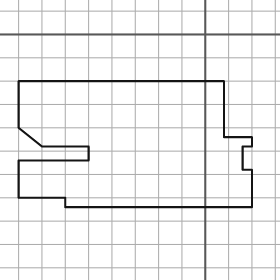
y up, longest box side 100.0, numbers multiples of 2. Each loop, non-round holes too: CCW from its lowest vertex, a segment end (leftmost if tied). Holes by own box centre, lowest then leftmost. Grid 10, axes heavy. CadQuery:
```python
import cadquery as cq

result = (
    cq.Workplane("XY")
    .moveTo(-60.0, -74.0)
    .lineTo(20.0, -74.0)
    .lineTo(20.0, -58.0)
    .lineTo(16.0, -58.0)
    .lineTo(16.0, -48.0)
    .lineTo(20.0, -48.0)
    .lineTo(20.0, -44.0)
    .lineTo(8.0, -44.0)
    .lineTo(8.0, -20.0)
    .lineTo(-80.0, -20.0)
    .lineTo(-80.0, -40.0)
    .lineTo(-70.0, -48.0)
    .lineTo(-50.0, -48.0)
    .lineTo(-50.0, -54.0)
    .lineTo(-80.0, -54.0)
    .lineTo(-80.0, -70.0)
    .lineTo(-60.0, -70.0)
    .close()
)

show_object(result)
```